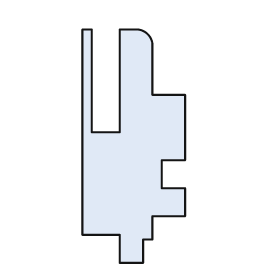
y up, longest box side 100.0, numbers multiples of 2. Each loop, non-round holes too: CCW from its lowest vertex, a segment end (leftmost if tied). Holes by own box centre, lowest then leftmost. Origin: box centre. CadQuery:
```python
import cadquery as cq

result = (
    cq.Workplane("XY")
    .moveTo(-6.0, -50.0)
    .lineTo(4.0, -50.0)
    .lineTo(4.0, -40.0)
    .lineTo(8.0, -40.0)
    .lineTo(8.0, -30.0)
    .lineTo(22.0, -30.0)
    .lineTo(22.0, -18.0)
    .lineTo(12.0, -18.0)
    .lineTo(12.0, -6.0)
    .lineTo(22.0, -6.0)
    .lineTo(22.0, 22.0)
    .lineTo(8.0, 22.0)
    .lineTo(8.0, 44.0)
    .threePointArc((6.0, 48.0), (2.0, 50.0))
    .lineTo(-6.0, 50.0)
    .lineTo(-6.0, 6.0)
    .lineTo(-18.0, 6.0)
    .lineTo(-18.0, 50.0)
    .lineTo(-22.0, 50.0)
    .lineTo(-22.0, -38.0)
    .lineTo(-6.0, -38.0)
    .close()
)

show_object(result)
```